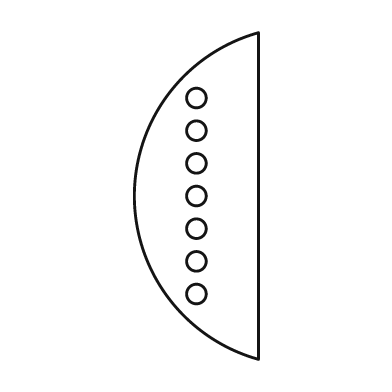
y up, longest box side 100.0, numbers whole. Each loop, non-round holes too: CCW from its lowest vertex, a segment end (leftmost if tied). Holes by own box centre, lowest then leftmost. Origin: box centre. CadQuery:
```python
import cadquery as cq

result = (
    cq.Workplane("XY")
    .moveTo(19.0, -50.0)
    .lineTo(19.0, 50.0)
    .threePointArc((-19.0, 0.0), (19.0, -50.0))
    .close()
    .moveTo(0.0, -30.0)
    .circle(3.0)
    .moveTo(0.0, -20.0)
    .circle(3.0)
    .moveTo(0.0, -10.0)
    .circle(3.0)
    .moveTo(0.0, 0.0)
    .circle(3.0)
    .moveTo(0.0, 10.0)
    .circle(3.0)
    .moveTo(0.0, 20.0)
    .circle(3.0)
    .moveTo(0.0, 30.0)
    .circle(3.0)
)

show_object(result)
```